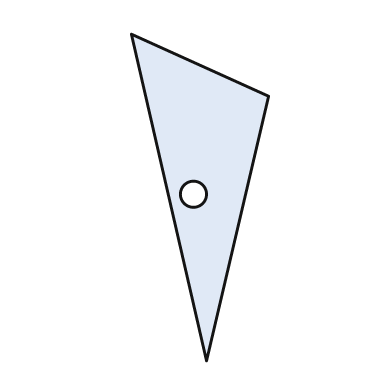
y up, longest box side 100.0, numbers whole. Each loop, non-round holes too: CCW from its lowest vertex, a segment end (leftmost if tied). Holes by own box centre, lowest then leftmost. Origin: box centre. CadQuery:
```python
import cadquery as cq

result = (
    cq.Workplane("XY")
    .moveTo(2.0, -50.0)
    .lineTo(21.0, 31.0)
    .lineTo(-21.0, 50.0)
    .close()
    .moveTo(-2.0, 1.0)
    .circle(4.0)
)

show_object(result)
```